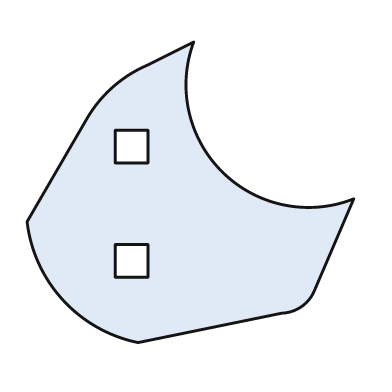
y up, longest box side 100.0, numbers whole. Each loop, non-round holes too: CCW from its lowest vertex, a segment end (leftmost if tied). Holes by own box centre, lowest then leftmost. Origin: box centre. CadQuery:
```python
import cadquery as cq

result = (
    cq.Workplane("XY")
    .moveTo(-16.0, -46.0)
    .lineTo(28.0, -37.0)
    .threePointArc((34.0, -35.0), (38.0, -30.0))
    .lineTo(50.0, -2.0)
    .threePointArc((10.0, 6.0), (1.0, 46.0))
    .lineTo(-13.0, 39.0)
    .threePointArc((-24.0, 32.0), (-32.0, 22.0))
    .lineTo(-50.0, -9.0)
    .threePointArc((-39.0, -33.0), (-16.0, -46.0))
    .close()
    .moveTo(-23.0, -26.0)
    .lineTo(-13.0, -26.0)
    .lineTo(-13.0, -16.0)
    .lineTo(-23.0, -16.0)
    .close()
    .moveTo(-23.0, 9.0)
    .lineTo(-13.0, 9.0)
    .lineTo(-13.0, 19.0)
    .lineTo(-23.0, 19.0)
    .close()
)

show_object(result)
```